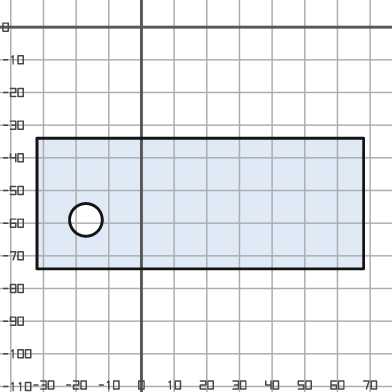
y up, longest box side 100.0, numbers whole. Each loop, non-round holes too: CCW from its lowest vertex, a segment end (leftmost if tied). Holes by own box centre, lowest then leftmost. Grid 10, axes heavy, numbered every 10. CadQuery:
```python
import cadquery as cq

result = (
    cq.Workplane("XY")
    .moveTo(-32.0, -74.0)
    .lineTo(68.0, -74.0)
    .lineTo(68.0, -34.0)
    .lineTo(-32.0, -34.0)
    .close()
    .moveTo(-17.0, -59.0)
    .circle(5.0)
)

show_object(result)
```